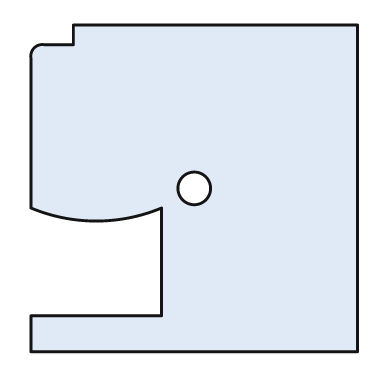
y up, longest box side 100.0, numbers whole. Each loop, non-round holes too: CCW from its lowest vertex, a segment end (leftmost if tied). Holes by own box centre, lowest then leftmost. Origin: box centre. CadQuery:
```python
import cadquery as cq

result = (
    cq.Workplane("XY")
    .moveTo(-50.0, -50.0)
    .lineTo(50.0, -50.0)
    .lineTo(50.0, 50.0)
    .lineTo(-37.0, 50.0)
    .lineTo(-37.0, 44.0)
    .lineTo(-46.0, 44.0)
    .threePointArc((-49.0, 43.0), (-50.0, 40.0))
    .lineTo(-50.0, -6.0)
    .threePointArc((-30.0, -10.0), (-10.0, -6.0))
    .lineTo(-10.0, -39.0)
    .lineTo(-50.0, -39.0)
    .close()
    .moveTo(0.0, 0.0)
    .circle(5.0)
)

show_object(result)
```